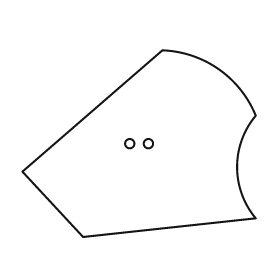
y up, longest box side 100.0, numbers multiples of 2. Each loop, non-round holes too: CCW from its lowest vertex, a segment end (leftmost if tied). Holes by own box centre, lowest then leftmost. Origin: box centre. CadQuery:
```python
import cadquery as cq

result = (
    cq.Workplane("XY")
    .moveTo(-24.0, -40.0)
    .lineTo(50.0, -32.0)
    .threePointArc((42.0, -10.0), (50.0, 12.0))
    .threePointArc((34.0, 32.0), (10.0, 40.0))
    .lineTo(-50.0, -12.0)
    .close()
    .moveTo(-4.0, 0.0)
    .circle(2.0)
    .moveTo(4.0, 0.0)
    .circle(2.0)
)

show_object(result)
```